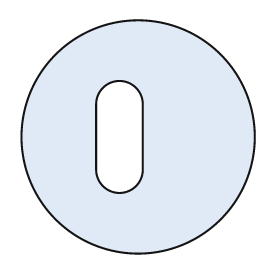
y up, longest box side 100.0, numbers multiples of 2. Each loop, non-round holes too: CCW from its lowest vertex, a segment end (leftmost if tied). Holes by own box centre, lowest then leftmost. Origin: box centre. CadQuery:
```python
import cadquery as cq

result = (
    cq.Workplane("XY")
    .moveTo(0.0, 0.0)
    .circle(50.0)
    .moveTo(-18.0, -14.0)
    .threePointArc((-8.0, -24.0), (2.0, -14.0))
    .lineTo(2.0, 14.0)
    .threePointArc((-8.0, 24.0), (-18.0, 14.0))
    .close()
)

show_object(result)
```